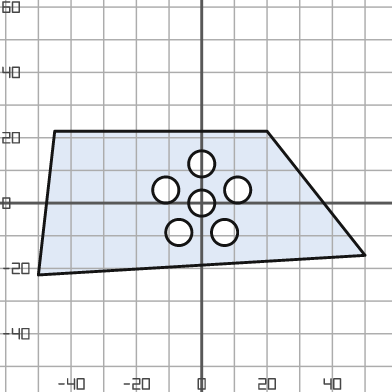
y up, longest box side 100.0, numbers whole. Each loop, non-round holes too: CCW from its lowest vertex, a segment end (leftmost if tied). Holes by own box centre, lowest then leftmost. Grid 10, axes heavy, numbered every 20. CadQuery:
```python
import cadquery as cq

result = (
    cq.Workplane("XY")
    .moveTo(-50.0, -22.0)
    .lineTo(50.0, -16.0)
    .lineTo(20.0, 22.0)
    .lineTo(-45.0, 22.0)
    .close()
    .moveTo(-7.0, -9.0)
    .circle(4.0)
    .moveTo(7.0, -9.0)
    .circle(4.0)
    .moveTo(0.0, 0.0)
    .circle(4.0)
    .moveTo(-11.0, 4.0)
    .circle(4.0)
    .moveTo(11.0, 4.0)
    .circle(4.0)
    .moveTo(0.0, 12.0)
    .circle(4.0)
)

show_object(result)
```